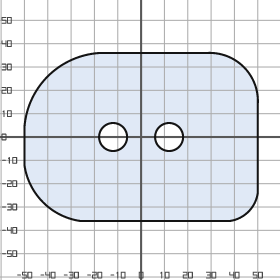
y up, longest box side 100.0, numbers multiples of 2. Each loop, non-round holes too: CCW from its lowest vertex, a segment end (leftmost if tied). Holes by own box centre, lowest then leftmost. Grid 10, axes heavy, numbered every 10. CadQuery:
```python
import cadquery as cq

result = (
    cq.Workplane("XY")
    .moveTo(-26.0, -36.0)
    .lineTo(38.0, -36.0)
    .threePointArc((46.0, -32.0), (50.0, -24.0))
    .lineTo(50.0, 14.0)
    .threePointArc((44.0, 30.0), (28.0, 36.0))
    .lineTo(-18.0, 36.0)
    .threePointArc((-40.0, 26.0), (-50.0, 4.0))
    .lineTo(-50.0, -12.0)
    .threePointArc((-42.0, -28.0), (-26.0, -36.0))
    .close()
    .moveTo(-12.0, 0.0)
    .circle(6.0)
    .moveTo(12.0, 0.0)
    .circle(6.0)
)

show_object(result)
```